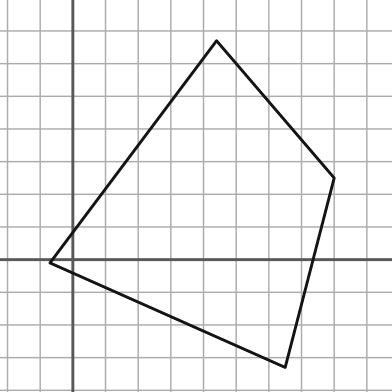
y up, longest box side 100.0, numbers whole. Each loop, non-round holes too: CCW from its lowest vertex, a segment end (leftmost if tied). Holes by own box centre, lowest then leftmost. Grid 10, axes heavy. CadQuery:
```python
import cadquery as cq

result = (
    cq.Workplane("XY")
    .moveTo(65.0, -33.0)
    .lineTo(80.0, 25.0)
    .lineTo(44.0, 67.0)
    .lineTo(-7.0, -1.0)
    .close()
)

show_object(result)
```